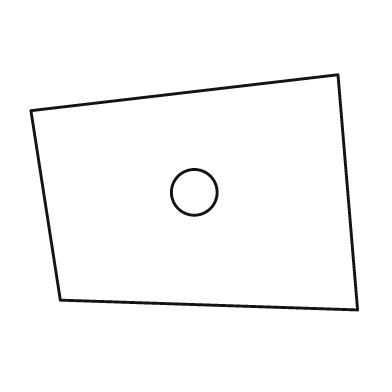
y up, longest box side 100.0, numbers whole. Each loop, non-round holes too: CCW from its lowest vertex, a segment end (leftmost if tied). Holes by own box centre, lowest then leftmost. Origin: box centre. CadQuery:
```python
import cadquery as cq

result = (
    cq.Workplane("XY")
    .moveTo(50.0, -36.0)
    .lineTo(44.0, 36.0)
    .lineTo(-50.0, 25.0)
    .lineTo(-41.0, -33.0)
    .close()
    .moveTo(0.0, 0.0)
    .circle(7.0)
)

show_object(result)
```